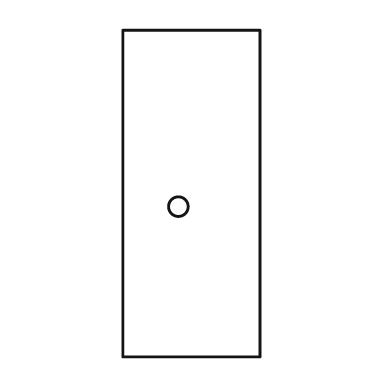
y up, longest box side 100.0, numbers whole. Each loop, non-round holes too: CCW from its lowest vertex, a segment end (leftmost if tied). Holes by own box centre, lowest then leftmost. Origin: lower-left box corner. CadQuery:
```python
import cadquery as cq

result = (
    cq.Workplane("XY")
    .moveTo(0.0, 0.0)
    .lineTo(42.0, 0.0)
    .lineTo(42.0, 100.0)
    .lineTo(0.0, 100.0)
    .close()
    .moveTo(17.0, 46.0)
    .circle(3.0)
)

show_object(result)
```